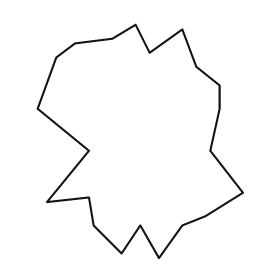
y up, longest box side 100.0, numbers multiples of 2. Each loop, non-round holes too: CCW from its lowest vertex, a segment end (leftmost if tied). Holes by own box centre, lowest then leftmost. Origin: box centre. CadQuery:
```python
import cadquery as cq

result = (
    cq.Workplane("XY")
    .moveTo(8.0, -50.0)
    .lineTo(18.0, -36.0)
    .lineTo(28.0, -32.0)
    .lineTo(44.0, -22.0)
    .lineTo(30.0, -4.0)
    .lineTo(34.0, 14.0)
    .lineTo(34.0, 24.0)
    .lineTo(24.0, 32.0)
    .lineTo(18.0, 48.0)
    .lineTo(4.0, 38.0)
    .lineTo(-2.0, 50.0)
    .lineTo(-12.0, 44.0)
    .lineTo(-28.0, 42.0)
    .lineTo(-36.0, 36.0)
    .lineTo(-44.0, 14.0)
    .lineTo(-22.0, -4.0)
    .lineTo(-40.0, -26.0)
    .lineTo(-22.0, -24.0)
    .lineTo(-20.0, -36.0)
    .lineTo(-8.0, -48.0)
    .lineTo(0.0, -36.0)
    .close()
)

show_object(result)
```